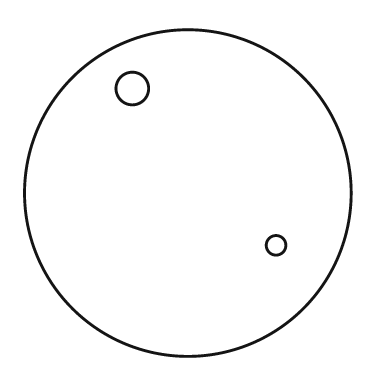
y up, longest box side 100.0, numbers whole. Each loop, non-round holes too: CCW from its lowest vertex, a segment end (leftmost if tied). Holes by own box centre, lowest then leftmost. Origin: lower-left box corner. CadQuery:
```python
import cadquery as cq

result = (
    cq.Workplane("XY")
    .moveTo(50.0, 50.0)
    .circle(50.0)
    .moveTo(77.0, 34.0)
    .circle(3.0)
    .moveTo(33.0, 82.0)
    .circle(5.0)
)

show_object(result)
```